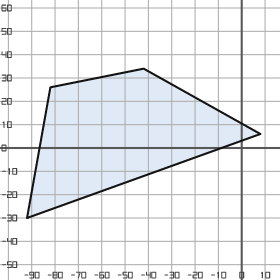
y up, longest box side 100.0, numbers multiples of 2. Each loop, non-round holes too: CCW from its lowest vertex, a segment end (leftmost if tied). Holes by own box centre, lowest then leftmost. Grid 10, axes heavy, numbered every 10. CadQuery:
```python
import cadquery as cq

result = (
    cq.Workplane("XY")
    .moveTo(-92.0, -30.0)
    .lineTo(8.0, 6.0)
    .lineTo(-42.0, 34.0)
    .lineTo(-82.0, 26.0)
    .close()
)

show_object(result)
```